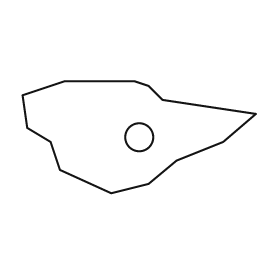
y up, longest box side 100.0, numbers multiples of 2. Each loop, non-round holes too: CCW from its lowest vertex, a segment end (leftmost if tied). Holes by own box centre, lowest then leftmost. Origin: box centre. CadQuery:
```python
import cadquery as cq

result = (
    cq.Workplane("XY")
    .moveTo(-12.0, -24.0)
    .lineTo(4.0, -20.0)
    .lineTo(16.0, -10.0)
    .lineTo(36.0, -2.0)
    .lineTo(50.0, 10.0)
    .lineTo(10.0, 16.0)
    .lineTo(4.0, 22.0)
    .lineTo(-2.0, 24.0)
    .lineTo(-32.0, 24.0)
    .lineTo(-50.0, 18.0)
    .lineTo(-48.0, 4.0)
    .lineTo(-38.0, -2.0)
    .lineTo(-34.0, -14.0)
    .close()
    .moveTo(0.0, 0.0)
    .circle(6.0)
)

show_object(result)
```